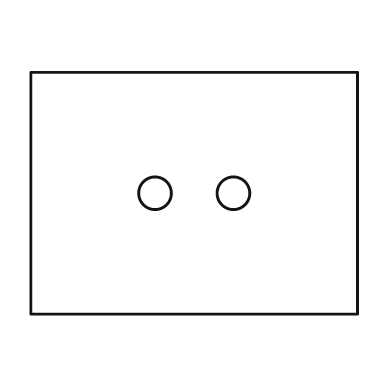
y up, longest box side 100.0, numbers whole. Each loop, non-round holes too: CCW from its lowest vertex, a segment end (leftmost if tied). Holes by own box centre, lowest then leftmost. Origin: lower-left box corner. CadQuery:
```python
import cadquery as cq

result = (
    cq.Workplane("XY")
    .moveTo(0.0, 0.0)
    .lineTo(100.0, 0.0)
    .lineTo(100.0, 74.0)
    .lineTo(0.0, 74.0)
    .close()
    .moveTo(38.0, 37.0)
    .circle(5.0)
    .moveTo(62.0, 37.0)
    .circle(5.0)
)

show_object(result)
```